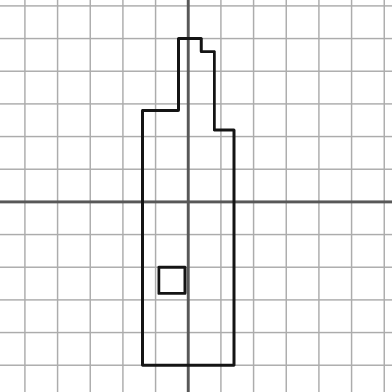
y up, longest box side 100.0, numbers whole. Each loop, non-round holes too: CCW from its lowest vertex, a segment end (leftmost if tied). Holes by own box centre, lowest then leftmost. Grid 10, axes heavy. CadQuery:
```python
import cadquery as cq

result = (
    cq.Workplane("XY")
    .moveTo(-14.0, -50.0)
    .lineTo(14.0, -50.0)
    .lineTo(14.0, 22.0)
    .lineTo(8.0, 22.0)
    .lineTo(8.0, 46.0)
    .lineTo(4.0, 46.0)
    .lineTo(4.0, 50.0)
    .lineTo(-3.0, 50.0)
    .lineTo(-3.0, 28.0)
    .lineTo(-14.0, 28.0)
    .close()
    .moveTo(-9.0, -28.0)
    .lineTo(-1.0, -28.0)
    .lineTo(-1.0, -20.0)
    .lineTo(-9.0, -20.0)
    .close()
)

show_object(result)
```